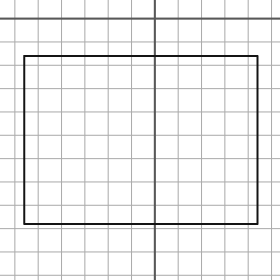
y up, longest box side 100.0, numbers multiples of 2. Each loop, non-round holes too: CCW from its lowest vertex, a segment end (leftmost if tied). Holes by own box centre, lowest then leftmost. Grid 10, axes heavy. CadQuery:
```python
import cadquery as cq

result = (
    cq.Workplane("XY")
    .moveTo(-56.0, -88.0)
    .lineTo(44.0, -88.0)
    .lineTo(44.0, -16.0)
    .lineTo(-56.0, -16.0)
    .close()
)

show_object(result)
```